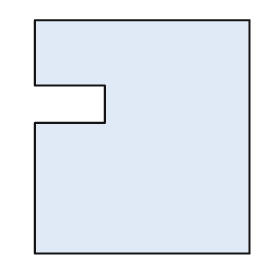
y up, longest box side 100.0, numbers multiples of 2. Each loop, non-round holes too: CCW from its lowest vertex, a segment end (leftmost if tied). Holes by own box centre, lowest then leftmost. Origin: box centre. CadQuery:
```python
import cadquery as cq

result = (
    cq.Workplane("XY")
    .moveTo(-46.0, -50.0)
    .lineTo(46.0, -50.0)
    .lineTo(46.0, 50.0)
    .lineTo(-46.0, 50.0)
    .lineTo(-46.0, 22.0)
    .lineTo(-16.0, 22.0)
    .lineTo(-16.0, 6.0)
    .lineTo(-46.0, 6.0)
    .close()
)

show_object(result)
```